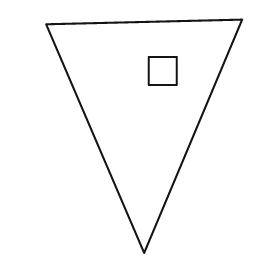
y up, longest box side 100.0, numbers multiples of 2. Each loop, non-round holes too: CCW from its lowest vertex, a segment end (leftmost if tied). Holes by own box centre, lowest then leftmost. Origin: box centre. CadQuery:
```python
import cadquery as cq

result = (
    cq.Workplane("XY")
    .moveTo(0.0, -50.0)
    .lineTo(42.0, 50.0)
    .lineTo(-42.0, 48.0)
    .close()
    .moveTo(2.0, 22.0)
    .lineTo(14.0, 22.0)
    .lineTo(14.0, 34.0)
    .lineTo(2.0, 34.0)
    .close()
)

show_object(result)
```